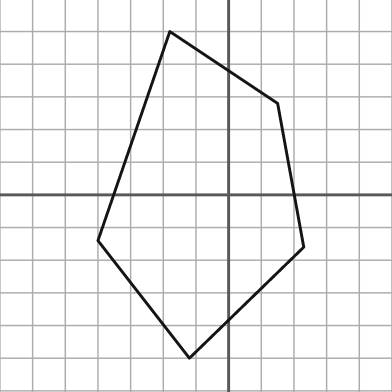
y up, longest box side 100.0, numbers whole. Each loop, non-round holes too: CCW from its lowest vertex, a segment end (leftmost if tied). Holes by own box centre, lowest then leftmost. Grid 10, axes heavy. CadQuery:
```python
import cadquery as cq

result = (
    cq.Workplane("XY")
    .moveTo(-12.0, -50.0)
    .lineTo(23.0, -16.0)
    .lineTo(15.0, 28.0)
    .lineTo(-18.0, 50.0)
    .lineTo(-40.0, -14.0)
    .close()
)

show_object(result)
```